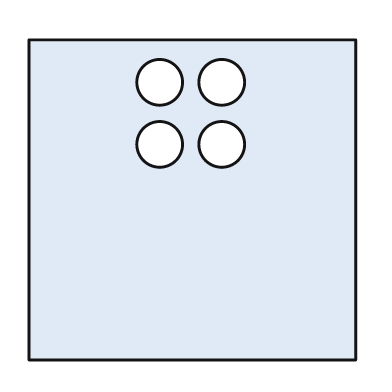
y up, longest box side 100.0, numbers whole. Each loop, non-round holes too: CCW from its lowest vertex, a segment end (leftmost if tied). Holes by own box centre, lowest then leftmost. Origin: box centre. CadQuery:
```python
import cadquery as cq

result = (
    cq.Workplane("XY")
    .moveTo(-50.0, -49.0)
    .lineTo(50.0, -49.0)
    .lineTo(50.0, 49.0)
    .lineTo(-50.0, 49.0)
    .close()
    .moveTo(-10.0, 17.0)
    .circle(7.0)
    .moveTo(9.0, 17.0)
    .circle(7.0)
    .moveTo(-10.0, 36.0)
    .circle(7.0)
    .moveTo(9.0, 36.0)
    .circle(7.0)
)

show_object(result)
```